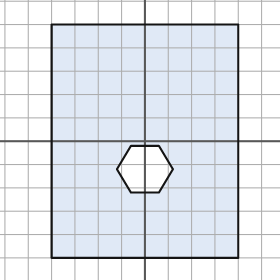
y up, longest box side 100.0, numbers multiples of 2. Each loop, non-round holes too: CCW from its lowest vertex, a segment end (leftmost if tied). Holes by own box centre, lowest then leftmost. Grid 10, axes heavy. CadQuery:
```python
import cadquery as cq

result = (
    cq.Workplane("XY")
    .moveTo(-40.0, -50.0)
    .lineTo(40.0, -50.0)
    .lineTo(40.0, 50.0)
    .lineTo(-40.0, 50.0)
    .close()
    .moveTo(-6.0, -22.0)
    .lineTo(6.0, -22.0)
    .lineTo(12.0, -12.0)
    .lineTo(6.0, -2.0)
    .lineTo(-6.0, -2.0)
    .lineTo(-12.0, -12.0)
    .close()
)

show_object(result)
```